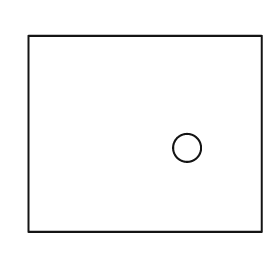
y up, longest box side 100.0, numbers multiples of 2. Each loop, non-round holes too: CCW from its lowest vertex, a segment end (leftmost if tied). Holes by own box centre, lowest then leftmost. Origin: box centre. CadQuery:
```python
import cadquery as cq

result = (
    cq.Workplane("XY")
    .moveTo(-50.0, -42.0)
    .lineTo(50.0, -42.0)
    .lineTo(50.0, 42.0)
    .lineTo(-50.0, 42.0)
    .close()
    .moveTo(18.0, -6.0)
    .circle(6.0)
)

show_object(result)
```